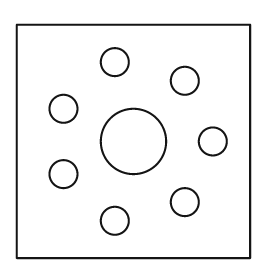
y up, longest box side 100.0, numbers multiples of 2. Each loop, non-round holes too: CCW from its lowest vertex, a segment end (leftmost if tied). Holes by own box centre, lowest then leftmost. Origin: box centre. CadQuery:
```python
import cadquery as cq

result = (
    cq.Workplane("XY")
    .moveTo(-50.0, -50.0)
    .lineTo(50.0, -50.0)
    .lineTo(50.0, 50.0)
    .lineTo(-50.0, 50.0)
    .close()
    .moveTo(-8.0, -34.0)
    .circle(6.0)
    .moveTo(22.0, -26.0)
    .circle(6.0)
    .moveTo(-30.0, -14.0)
    .circle(6.0)
    .moveTo(0.0, 0.0)
    .circle(14.0)
    .moveTo(34.0, 0.0)
    .circle(6.0)
    .moveTo(-30.0, 14.0)
    .circle(6.0)
    .moveTo(22.0, 26.0)
    .circle(6.0)
    .moveTo(-8.0, 34.0)
    .circle(6.0)
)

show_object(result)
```